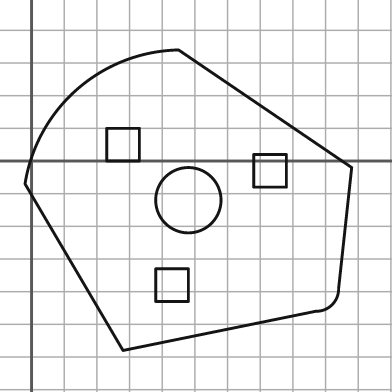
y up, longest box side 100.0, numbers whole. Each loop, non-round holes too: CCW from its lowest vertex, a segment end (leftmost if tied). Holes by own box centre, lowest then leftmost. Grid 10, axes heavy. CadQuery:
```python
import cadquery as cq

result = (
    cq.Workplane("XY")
    .moveTo(28.0, -58.0)
    .lineTo(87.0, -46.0)
    .threePointArc((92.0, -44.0), (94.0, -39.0))
    .lineTo(98.0, -2.0)
    .lineTo(45.0, 34.0)
    .threePointArc((14.0, 22.0), (-2.0, -7.0))
    .close()
    .moveTo(38.0, -43.0)
    .lineTo(48.0, -43.0)
    .lineTo(48.0, -33.0)
    .lineTo(38.0, -33.0)
    .close()
    .moveTo(48.0, -12.0)
    .circle(10.0)
    .moveTo(68.0, -8.0)
    .lineTo(78.0, -8.0)
    .lineTo(78.0, 2.0)
    .lineTo(68.0, 2.0)
    .close()
    .moveTo(23.0, 0.0)
    .lineTo(33.0, 0.0)
    .lineTo(33.0, 10.0)
    .lineTo(23.0, 10.0)
    .close()
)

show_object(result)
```